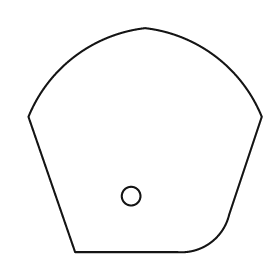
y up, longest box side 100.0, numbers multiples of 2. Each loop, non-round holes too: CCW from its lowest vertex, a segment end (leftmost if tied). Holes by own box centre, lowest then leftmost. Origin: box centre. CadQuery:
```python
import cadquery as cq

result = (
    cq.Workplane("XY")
    .moveTo(-30.0, -48.0)
    .lineTo(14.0, -48.0)
    .threePointArc((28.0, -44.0), (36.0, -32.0))
    .lineTo(50.0, 10.0)
    .threePointArc((30.0, 36.0), (0.0, 48.0))
    .threePointArc((-30.0, 36.0), (-50.0, 10.0))
    .close()
    .moveTo(-6.0, -24.0)
    .circle(4.0)
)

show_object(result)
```